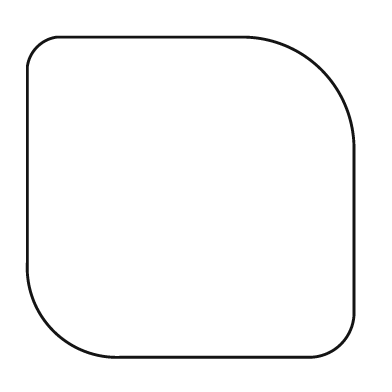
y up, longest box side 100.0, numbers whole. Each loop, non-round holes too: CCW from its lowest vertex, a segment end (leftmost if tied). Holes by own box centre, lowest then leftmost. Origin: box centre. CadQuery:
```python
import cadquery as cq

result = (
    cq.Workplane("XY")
    .moveTo(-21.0, -49.0)
    .lineTo(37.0, -49.0)
    .threePointArc((46.0, -45.0), (50.0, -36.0))
    .lineTo(50.0, 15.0)
    .threePointArc((40.0, 39.0), (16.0, 49.0))
    .lineTo(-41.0, 49.0)
    .threePointArc((-47.0, 46.0), (-50.0, 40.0))
    .lineTo(-50.0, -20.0)
    .threePointArc((-42.0, -41.0), (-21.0, -49.0))
    .close()
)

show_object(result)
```